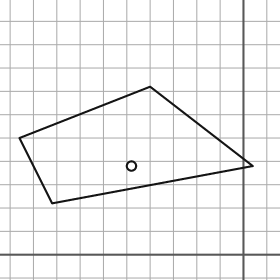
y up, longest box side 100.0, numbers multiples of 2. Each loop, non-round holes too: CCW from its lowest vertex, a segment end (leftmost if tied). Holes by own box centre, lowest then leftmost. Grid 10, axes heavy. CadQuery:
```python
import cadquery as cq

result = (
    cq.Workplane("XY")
    .moveTo(-82.0, 22.0)
    .lineTo(4.0, 38.0)
    .lineTo(-40.0, 72.0)
    .lineTo(-96.0, 50.0)
    .close()
    .moveTo(-48.0, 38.0)
    .circle(2.0)
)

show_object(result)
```